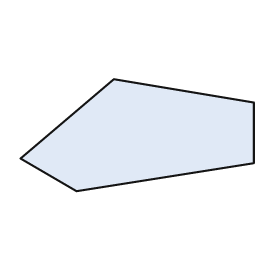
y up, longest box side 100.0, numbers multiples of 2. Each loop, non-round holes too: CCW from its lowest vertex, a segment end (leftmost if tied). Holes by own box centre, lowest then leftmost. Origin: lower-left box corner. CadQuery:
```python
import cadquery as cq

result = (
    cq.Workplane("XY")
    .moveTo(24.0, 0.0)
    .lineTo(100.0, 12.0)
    .lineTo(100.0, 38.0)
    .lineTo(40.0, 48.0)
    .lineTo(0.0, 14.0)
    .close()
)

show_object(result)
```